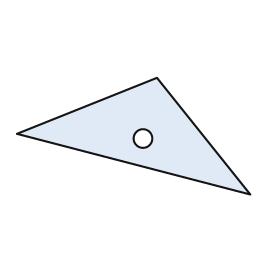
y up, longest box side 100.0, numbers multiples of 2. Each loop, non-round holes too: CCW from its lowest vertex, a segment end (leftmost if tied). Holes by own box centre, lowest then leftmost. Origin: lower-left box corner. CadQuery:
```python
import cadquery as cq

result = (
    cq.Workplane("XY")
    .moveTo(100.0, 0.0)
    .lineTo(60.0, 50.0)
    .lineTo(0.0, 26.0)
    .close()
    .moveTo(54.0, 24.0)
    .circle(4.0)
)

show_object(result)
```